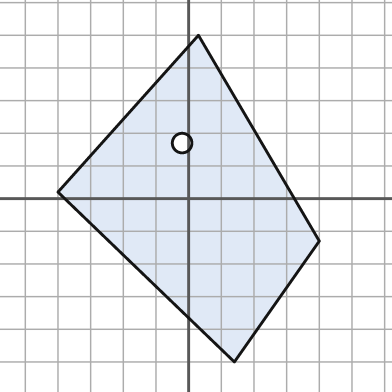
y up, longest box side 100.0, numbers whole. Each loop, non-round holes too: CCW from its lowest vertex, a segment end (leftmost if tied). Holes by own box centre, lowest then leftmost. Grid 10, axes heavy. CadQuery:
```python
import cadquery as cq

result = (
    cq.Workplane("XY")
    .moveTo(14.0, -50.0)
    .lineTo(40.0, -13.0)
    .lineTo(3.0, 50.0)
    .lineTo(-40.0, 2.0)
    .close()
    .moveTo(-2.0, 17.0)
    .circle(3.0)
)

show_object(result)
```